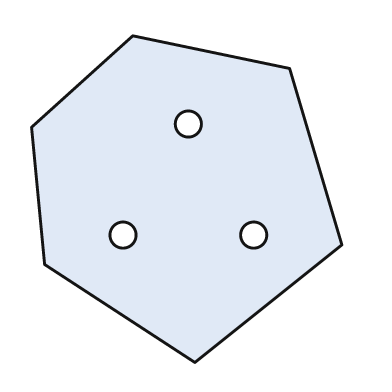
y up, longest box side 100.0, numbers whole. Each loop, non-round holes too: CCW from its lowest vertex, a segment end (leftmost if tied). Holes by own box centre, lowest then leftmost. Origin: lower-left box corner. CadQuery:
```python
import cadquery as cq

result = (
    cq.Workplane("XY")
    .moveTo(50.0, 0.0)
    .lineTo(95.0, 36.0)
    .lineTo(79.0, 90.0)
    .lineTo(31.0, 100.0)
    .lineTo(0.0, 72.0)
    .lineTo(4.0, 30.0)
    .close()
    .moveTo(28.0, 39.0)
    .circle(4.0)
    .moveTo(68.0, 39.0)
    .circle(4.0)
    .moveTo(48.0, 73.0)
    .circle(4.0)
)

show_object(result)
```